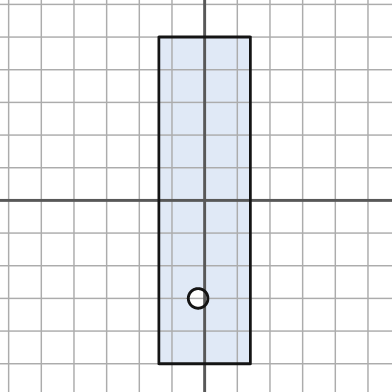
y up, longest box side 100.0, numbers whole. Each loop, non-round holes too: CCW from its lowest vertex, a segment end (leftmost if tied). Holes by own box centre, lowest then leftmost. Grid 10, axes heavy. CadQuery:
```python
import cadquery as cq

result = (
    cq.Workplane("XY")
    .moveTo(-14.0, -50.0)
    .lineTo(14.0, -50.0)
    .lineTo(14.0, 50.0)
    .lineTo(-14.0, 50.0)
    .close()
    .moveTo(-2.0, -30.0)
    .circle(3.0)
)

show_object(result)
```